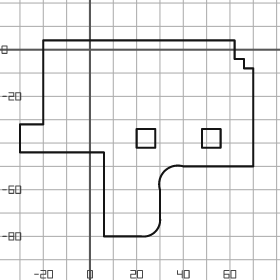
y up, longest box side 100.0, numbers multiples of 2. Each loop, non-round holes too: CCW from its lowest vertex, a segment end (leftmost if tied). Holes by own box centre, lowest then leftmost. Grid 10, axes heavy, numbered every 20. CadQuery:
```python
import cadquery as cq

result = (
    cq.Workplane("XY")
    .moveTo(6.0, -80.0)
    .lineTo(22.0, -80.0)
    .threePointArc((28.0, -78.0), (30.0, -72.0))
    .lineTo(30.0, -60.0)
    .threePointArc((32.0, -52.0), (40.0, -50.0))
    .lineTo(70.0, -50.0)
    .lineTo(70.0, -8.0)
    .lineTo(66.0, -8.0)
    .lineTo(66.0, -4.0)
    .lineTo(62.0, -4.0)
    .lineTo(62.0, 4.0)
    .lineTo(-20.0, 4.0)
    .lineTo(-20.0, -32.0)
    .lineTo(-30.0, -32.0)
    .lineTo(-30.0, -44.0)
    .lineTo(6.0, -44.0)
    .close()
    .moveTo(20.0, -42.0)
    .lineTo(28.0, -42.0)
    .lineTo(28.0, -34.0)
    .lineTo(20.0, -34.0)
    .close()
    .moveTo(48.0, -42.0)
    .lineTo(56.0, -42.0)
    .lineTo(56.0, -34.0)
    .lineTo(48.0, -34.0)
    .close()
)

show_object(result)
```